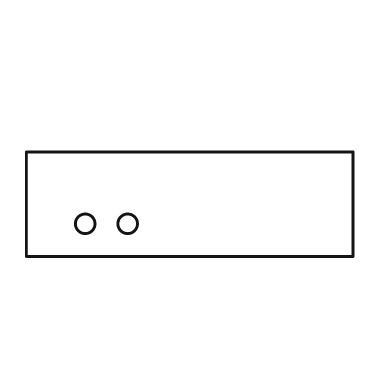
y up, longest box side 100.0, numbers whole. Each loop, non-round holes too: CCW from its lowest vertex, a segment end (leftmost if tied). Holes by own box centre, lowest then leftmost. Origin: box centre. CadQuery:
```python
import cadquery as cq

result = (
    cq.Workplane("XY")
    .moveTo(-50.0, -16.0)
    .lineTo(50.0, -16.0)
    .lineTo(50.0, 16.0)
    .lineTo(-50.0, 16.0)
    .close()
    .moveTo(-32.0, -6.0)
    .circle(3.0)
    .moveTo(-19.0, -6.0)
    .circle(3.0)
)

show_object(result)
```